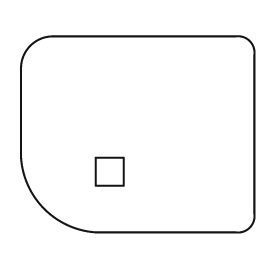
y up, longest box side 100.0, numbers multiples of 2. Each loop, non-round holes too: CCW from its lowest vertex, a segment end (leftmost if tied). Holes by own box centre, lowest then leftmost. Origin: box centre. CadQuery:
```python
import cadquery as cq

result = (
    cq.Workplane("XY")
    .moveTo(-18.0, -42.0)
    .lineTo(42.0, -42.0)
    .threePointArc((48.0, -40.0), (50.0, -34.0))
    .lineTo(50.0, 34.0)
    .threePointArc((48.0, 40.0), (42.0, 42.0))
    .lineTo(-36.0, 42.0)
    .threePointArc((-46.0, 38.0), (-50.0, 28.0))
    .lineTo(-50.0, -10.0)
    .threePointArc((-40.0, -32.0), (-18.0, -42.0))
    .close()
    .moveTo(-18.0, -22.0)
    .lineTo(-6.0, -22.0)
    .lineTo(-6.0, -10.0)
    .lineTo(-18.0, -10.0)
    .close()
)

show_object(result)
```